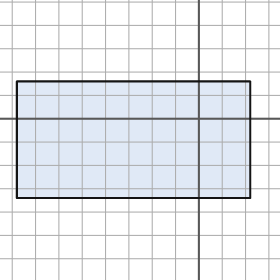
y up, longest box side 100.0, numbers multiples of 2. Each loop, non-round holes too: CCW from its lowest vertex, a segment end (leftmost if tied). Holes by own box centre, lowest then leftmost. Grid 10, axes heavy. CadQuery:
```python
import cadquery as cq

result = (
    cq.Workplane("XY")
    .moveTo(-78.0, -34.0)
    .lineTo(22.0, -34.0)
    .lineTo(22.0, 16.0)
    .lineTo(-78.0, 16.0)
    .close()
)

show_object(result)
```